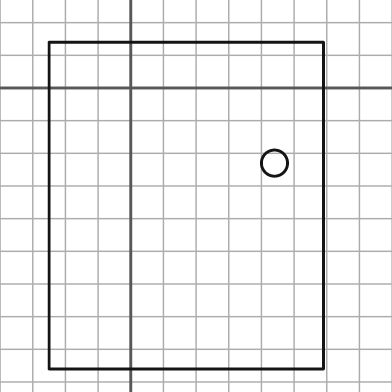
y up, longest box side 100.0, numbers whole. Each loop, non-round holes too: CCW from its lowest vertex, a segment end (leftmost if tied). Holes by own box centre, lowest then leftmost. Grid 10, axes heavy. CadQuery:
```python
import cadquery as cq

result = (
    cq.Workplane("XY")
    .moveTo(-25.0, -86.0)
    .lineTo(59.0, -86.0)
    .lineTo(59.0, 14.0)
    .lineTo(-25.0, 14.0)
    .close()
    .moveTo(44.0, -23.0)
    .circle(4.0)
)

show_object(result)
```